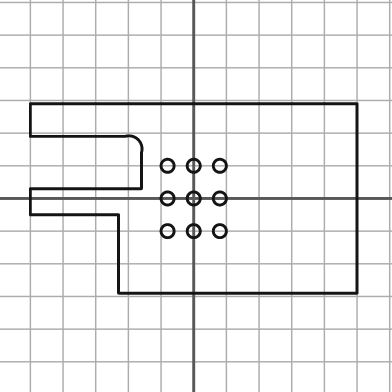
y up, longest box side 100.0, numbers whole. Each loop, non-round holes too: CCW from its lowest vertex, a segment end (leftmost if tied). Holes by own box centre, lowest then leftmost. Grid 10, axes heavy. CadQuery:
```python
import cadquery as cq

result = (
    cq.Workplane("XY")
    .moveTo(-23.0, -29.0)
    .lineTo(50.0, -29.0)
    .lineTo(50.0, 29.0)
    .lineTo(-50.0, 29.0)
    .lineTo(-50.0, 19.0)
    .lineTo(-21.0, 19.0)
    .threePointArc((-17.0, 18.0), (-16.0, 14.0))
    .lineTo(-16.0, 3.0)
    .lineTo(-50.0, 3.0)
    .lineTo(-50.0, -5.0)
    .lineTo(-23.0, -5.0)
    .close()
    .moveTo(-8.0, -10.0)
    .circle(2.0)
    .moveTo(0.0, -10.0)
    .circle(2.0)
    .moveTo(8.0, -10.0)
    .circle(2.0)
    .moveTo(-8.0, 0.0)
    .circle(2.0)
    .moveTo(0.0, 0.0)
    .circle(2.0)
    .moveTo(8.0, 0.0)
    .circle(2.0)
    .moveTo(-8.0, 10.0)
    .circle(2.0)
    .moveTo(0.0, 10.0)
    .circle(2.0)
    .moveTo(8.0, 10.0)
    .circle(2.0)
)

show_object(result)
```